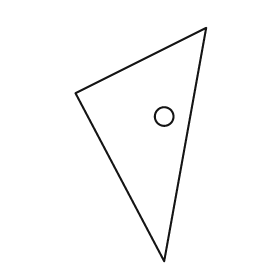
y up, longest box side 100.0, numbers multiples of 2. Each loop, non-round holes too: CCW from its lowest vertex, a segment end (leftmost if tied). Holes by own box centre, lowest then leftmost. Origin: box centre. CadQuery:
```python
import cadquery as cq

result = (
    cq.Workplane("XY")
    .moveTo(10.0, -50.0)
    .lineTo(28.0, 50.0)
    .lineTo(-28.0, 22.0)
    .close()
    .moveTo(10.0, 12.0)
    .circle(4.0)
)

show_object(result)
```